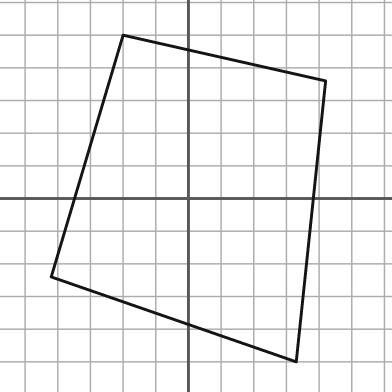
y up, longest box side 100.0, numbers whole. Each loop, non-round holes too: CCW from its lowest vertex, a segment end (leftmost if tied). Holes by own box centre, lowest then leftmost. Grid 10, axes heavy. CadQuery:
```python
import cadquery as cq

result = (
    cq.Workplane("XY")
    .moveTo(33.0, -50.0)
    .lineTo(42.0, 36.0)
    .lineTo(-20.0, 50.0)
    .lineTo(-42.0, -24.0)
    .close()
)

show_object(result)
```